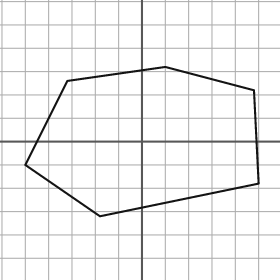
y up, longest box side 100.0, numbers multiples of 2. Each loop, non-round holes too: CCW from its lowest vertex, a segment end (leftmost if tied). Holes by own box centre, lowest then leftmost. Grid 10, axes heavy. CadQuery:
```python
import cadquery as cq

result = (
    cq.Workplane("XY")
    .moveTo(-18.0, -32.0)
    .lineTo(50.0, -18.0)
    .lineTo(48.0, 22.0)
    .lineTo(10.0, 32.0)
    .lineTo(-32.0, 26.0)
    .lineTo(-50.0, -10.0)
    .close()
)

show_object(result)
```